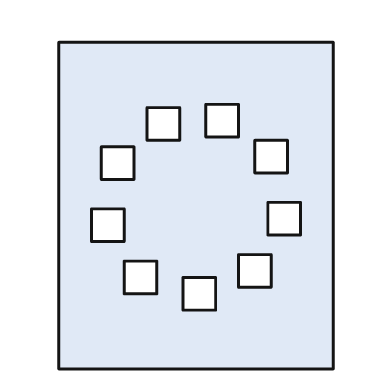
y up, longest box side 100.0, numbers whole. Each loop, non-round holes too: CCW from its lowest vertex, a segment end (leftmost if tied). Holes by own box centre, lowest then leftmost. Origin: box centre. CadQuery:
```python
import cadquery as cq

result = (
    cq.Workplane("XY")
    .moveTo(-42.0, -50.0)
    .lineTo(42.0, -50.0)
    .lineTo(42.0, 50.0)
    .lineTo(-42.0, 50.0)
    .close()
    .moveTo(-4.0, -32.0)
    .lineTo(6.0, -32.0)
    .lineTo(6.0, -22.0)
    .lineTo(-4.0, -22.0)
    .close()
    .moveTo(-22.0, -27.0)
    .lineTo(-12.0, -27.0)
    .lineTo(-12.0, -17.0)
    .lineTo(-22.0, -17.0)
    .close()
    .moveTo(13.0, -25.0)
    .lineTo(23.0, -25.0)
    .lineTo(23.0, -15.0)
    .lineTo(13.0, -15.0)
    .close()
    .moveTo(-32.0, -11.0)
    .lineTo(-22.0, -11.0)
    .lineTo(-22.0, -1.0)
    .lineTo(-32.0, -1.0)
    .close()
    .moveTo(22.0, -9.0)
    .lineTo(32.0, -9.0)
    .lineTo(32.0, 1.0)
    .lineTo(22.0, 1.0)
    .close()
    .moveTo(-29.0, 8.0)
    .lineTo(-19.0, 8.0)
    .lineTo(-19.0, 18.0)
    .lineTo(-29.0, 18.0)
    .close()
    .moveTo(18.0, 10.0)
    .lineTo(28.0, 10.0)
    .lineTo(28.0, 20.0)
    .lineTo(18.0, 20.0)
    .close()
    .moveTo(-15.0, 20.0)
    .lineTo(-5.0, 20.0)
    .lineTo(-5.0, 30.0)
    .lineTo(-15.0, 30.0)
    .close()
    .moveTo(3.0, 21.0)
    .lineTo(13.0, 21.0)
    .lineTo(13.0, 31.0)
    .lineTo(3.0, 31.0)
    .close()
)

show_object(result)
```